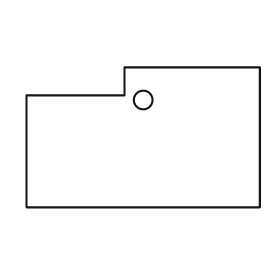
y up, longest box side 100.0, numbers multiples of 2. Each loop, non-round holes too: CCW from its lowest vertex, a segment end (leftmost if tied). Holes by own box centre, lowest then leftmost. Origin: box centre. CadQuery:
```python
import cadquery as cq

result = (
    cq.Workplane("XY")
    .moveTo(-50.0, -30.0)
    .lineTo(50.0, -30.0)
    .lineTo(50.0, 30.0)
    .lineTo(-8.0, 30.0)
    .lineTo(-8.0, 18.0)
    .lineTo(-50.0, 18.0)
    .close()
    .moveTo(0.0, 16.0)
    .circle(4.0)
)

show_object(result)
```